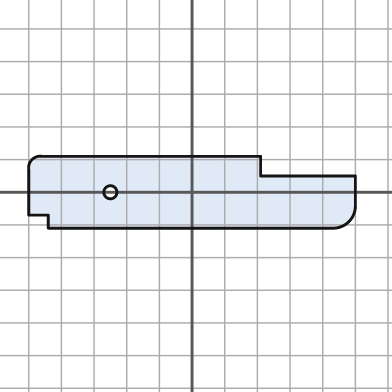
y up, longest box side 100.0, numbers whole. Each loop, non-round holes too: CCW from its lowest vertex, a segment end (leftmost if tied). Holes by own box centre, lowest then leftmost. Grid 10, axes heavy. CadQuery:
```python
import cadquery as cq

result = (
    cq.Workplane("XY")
    .moveTo(-44.0, -11.0)
    .lineTo(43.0, -11.0)
    .threePointArc((48.0, -9.0), (50.0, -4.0))
    .lineTo(50.0, 5.0)
    .lineTo(21.0, 5.0)
    .lineTo(21.0, 11.0)
    .lineTo(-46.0, 11.0)
    .threePointArc((-49.0, 10.0), (-50.0, 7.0))
    .lineTo(-50.0, -7.0)
    .lineTo(-44.0, -7.0)
    .close()
    .moveTo(-25.0, 0.0)
    .circle(2.0)
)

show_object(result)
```